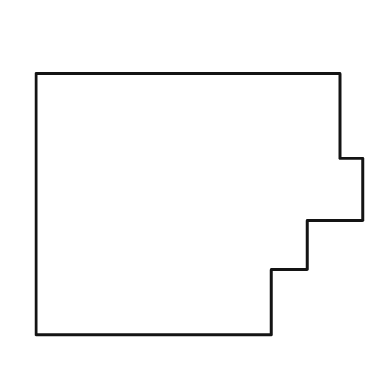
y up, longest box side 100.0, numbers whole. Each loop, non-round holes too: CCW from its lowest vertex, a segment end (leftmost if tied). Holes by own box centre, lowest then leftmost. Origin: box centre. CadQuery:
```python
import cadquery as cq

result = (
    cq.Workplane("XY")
    .moveTo(-50.0, -40.0)
    .lineTo(22.0, -40.0)
    .lineTo(22.0, -20.0)
    .lineTo(33.0, -20.0)
    .lineTo(33.0, -5.0)
    .lineTo(50.0, -5.0)
    .lineTo(50.0, 14.0)
    .lineTo(43.0, 14.0)
    .lineTo(43.0, 40.0)
    .lineTo(-50.0, 40.0)
    .close()
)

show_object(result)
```